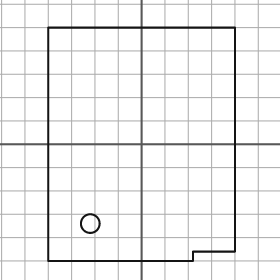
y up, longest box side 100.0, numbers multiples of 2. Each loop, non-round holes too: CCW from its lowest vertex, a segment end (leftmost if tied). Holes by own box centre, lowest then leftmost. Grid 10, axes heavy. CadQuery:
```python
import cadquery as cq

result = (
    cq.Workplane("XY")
    .moveTo(-40.0, -50.0)
    .lineTo(22.0, -50.0)
    .lineTo(22.0, -46.0)
    .lineTo(40.0, -46.0)
    .lineTo(40.0, 50.0)
    .lineTo(-40.0, 50.0)
    .close()
    .moveTo(-22.0, -34.0)
    .circle(4.0)
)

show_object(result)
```